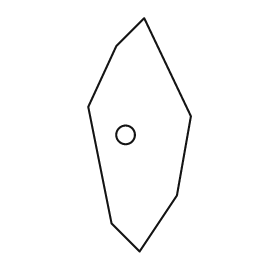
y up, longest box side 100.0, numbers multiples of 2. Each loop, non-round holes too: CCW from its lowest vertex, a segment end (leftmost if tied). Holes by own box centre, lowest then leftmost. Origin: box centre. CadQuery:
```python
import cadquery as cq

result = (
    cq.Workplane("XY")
    .moveTo(0.0, -50.0)
    .lineTo(16.0, -26.0)
    .lineTo(22.0, 8.0)
    .lineTo(2.0, 50.0)
    .lineTo(-10.0, 38.0)
    .lineTo(-22.0, 12.0)
    .lineTo(-12.0, -38.0)
    .close()
    .moveTo(-6.0, 0.0)
    .circle(4.0)
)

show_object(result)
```